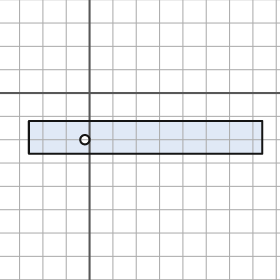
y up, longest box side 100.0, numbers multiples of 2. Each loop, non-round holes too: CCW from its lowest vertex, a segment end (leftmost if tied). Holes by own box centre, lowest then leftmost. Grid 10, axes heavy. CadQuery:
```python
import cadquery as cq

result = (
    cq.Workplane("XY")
    .moveTo(-26.0, -26.0)
    .lineTo(74.0, -26.0)
    .lineTo(74.0, -12.0)
    .lineTo(-26.0, -12.0)
    .close()
    .moveTo(-2.0, -20.0)
    .circle(2.0)
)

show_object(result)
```